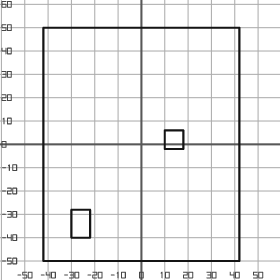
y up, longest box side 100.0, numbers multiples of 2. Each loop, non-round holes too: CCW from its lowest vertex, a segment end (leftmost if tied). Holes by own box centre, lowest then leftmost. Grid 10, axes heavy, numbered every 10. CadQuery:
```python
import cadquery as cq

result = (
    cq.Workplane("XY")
    .moveTo(-42.0, -50.0)
    .lineTo(42.0, -50.0)
    .lineTo(42.0, 50.0)
    .lineTo(-42.0, 50.0)
    .close()
    .moveTo(-30.0, -40.0)
    .lineTo(-22.0, -40.0)
    .lineTo(-22.0, -28.0)
    .lineTo(-30.0, -28.0)
    .close()
    .moveTo(10.0, -2.0)
    .lineTo(18.0, -2.0)
    .lineTo(18.0, 6.0)
    .lineTo(10.0, 6.0)
    .close()
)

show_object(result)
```